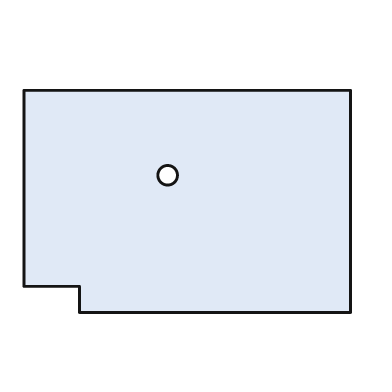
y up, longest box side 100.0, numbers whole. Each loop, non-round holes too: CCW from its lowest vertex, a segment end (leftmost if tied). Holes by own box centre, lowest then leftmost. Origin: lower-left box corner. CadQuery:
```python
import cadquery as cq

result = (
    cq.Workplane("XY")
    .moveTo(17.0, 0.0)
    .lineTo(100.0, 0.0)
    .lineTo(100.0, 68.0)
    .lineTo(0.0, 68.0)
    .lineTo(0.0, 8.0)
    .lineTo(17.0, 8.0)
    .close()
    .moveTo(44.0, 42.0)
    .circle(3.0)
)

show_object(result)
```